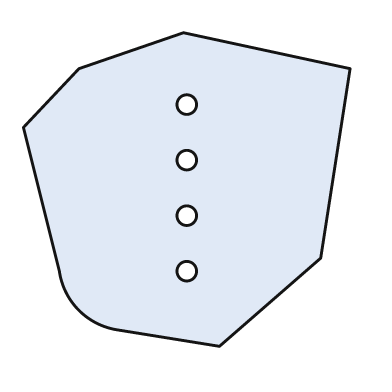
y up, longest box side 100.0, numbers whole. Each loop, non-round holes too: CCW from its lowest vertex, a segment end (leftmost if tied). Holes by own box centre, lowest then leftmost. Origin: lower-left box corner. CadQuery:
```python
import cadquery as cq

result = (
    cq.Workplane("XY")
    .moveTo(60.0, 0.0)
    .lineTo(91.0, 27.0)
    .lineTo(100.0, 85.0)
    .lineTo(49.0, 96.0)
    .lineTo(17.0, 85.0)
    .lineTo(0.0, 67.0)
    .lineTo(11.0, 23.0)
    .threePointArc((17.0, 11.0), (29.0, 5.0))
    .close()
    .moveTo(50.0, 23.0)
    .circle(3.0)
    .moveTo(50.0, 40.0)
    .circle(3.0)
    .moveTo(50.0, 57.0)
    .circle(3.0)
    .moveTo(50.0, 74.0)
    .circle(3.0)
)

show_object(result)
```